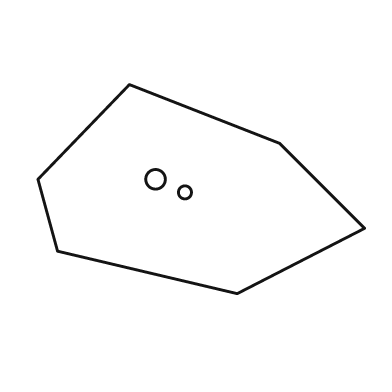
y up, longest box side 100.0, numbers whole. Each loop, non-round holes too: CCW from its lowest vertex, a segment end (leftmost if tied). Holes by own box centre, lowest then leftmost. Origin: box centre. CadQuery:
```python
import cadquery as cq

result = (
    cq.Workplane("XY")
    .moveTo(11.0, -32.0)
    .lineTo(50.0, -12.0)
    .lineTo(24.0, 14.0)
    .lineTo(-22.0, 32.0)
    .lineTo(-50.0, 3.0)
    .lineTo(-44.0, -19.0)
    .close()
    .moveTo(-5.0, -1.0)
    .circle(2.0)
    .moveTo(-14.0, 3.0)
    .circle(3.0)
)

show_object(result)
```